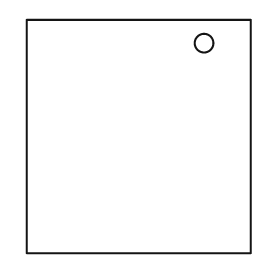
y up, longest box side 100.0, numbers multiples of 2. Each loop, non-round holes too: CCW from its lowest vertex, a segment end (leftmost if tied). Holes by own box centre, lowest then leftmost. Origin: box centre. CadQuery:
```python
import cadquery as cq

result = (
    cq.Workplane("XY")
    .moveTo(-48.0, -50.0)
    .lineTo(48.0, -50.0)
    .lineTo(48.0, 50.0)
    .lineTo(-48.0, 50.0)
    .close()
    .moveTo(28.0, 40.0)
    .circle(4.0)
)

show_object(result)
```